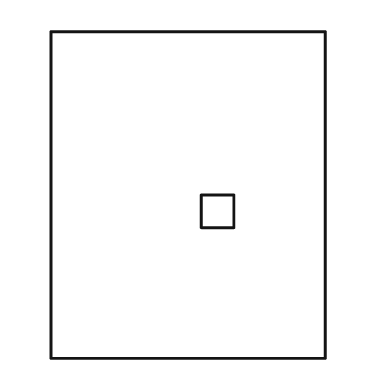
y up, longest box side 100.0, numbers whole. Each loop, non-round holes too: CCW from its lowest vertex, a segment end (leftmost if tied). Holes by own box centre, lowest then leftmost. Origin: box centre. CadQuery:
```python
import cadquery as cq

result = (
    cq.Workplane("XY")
    .moveTo(-42.0, -50.0)
    .lineTo(42.0, -50.0)
    .lineTo(42.0, 50.0)
    .lineTo(-42.0, 50.0)
    .close()
    .moveTo(4.0, -10.0)
    .lineTo(14.0, -10.0)
    .lineTo(14.0, 0.0)
    .lineTo(4.0, 0.0)
    .close()
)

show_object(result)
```